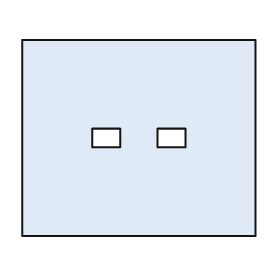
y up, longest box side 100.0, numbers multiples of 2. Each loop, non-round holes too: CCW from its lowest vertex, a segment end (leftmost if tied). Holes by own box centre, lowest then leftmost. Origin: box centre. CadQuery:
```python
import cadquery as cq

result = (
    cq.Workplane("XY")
    .moveTo(-50.0, -42.0)
    .lineTo(50.0, -42.0)
    .lineTo(50.0, 42.0)
    .lineTo(-50.0, 42.0)
    .close()
    .moveTo(-20.0, -4.0)
    .lineTo(-8.0, -4.0)
    .lineTo(-8.0, 4.0)
    .lineTo(-20.0, 4.0)
    .close()
    .moveTo(8.0, -4.0)
    .lineTo(20.0, -4.0)
    .lineTo(20.0, 4.0)
    .lineTo(8.0, 4.0)
    .close()
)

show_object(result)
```